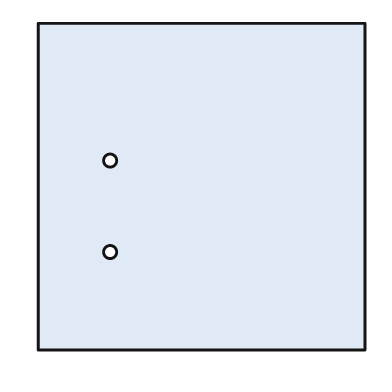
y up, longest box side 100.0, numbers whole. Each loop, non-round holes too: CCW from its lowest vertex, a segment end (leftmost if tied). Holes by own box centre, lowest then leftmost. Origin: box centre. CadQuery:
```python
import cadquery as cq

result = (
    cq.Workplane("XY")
    .moveTo(-50.0, -50.0)
    .lineTo(50.0, -50.0)
    .lineTo(50.0, 50.0)
    .lineTo(-50.0, 50.0)
    .close()
    .moveTo(-28.0, -20.0)
    .circle(2.0)
    .moveTo(-28.0, 8.0)
    .circle(2.0)
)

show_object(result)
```